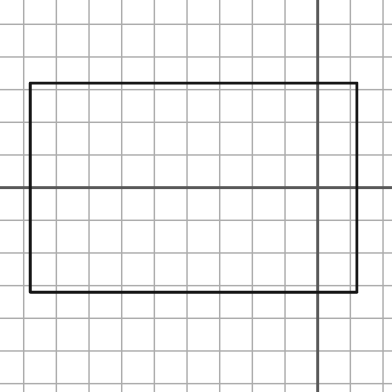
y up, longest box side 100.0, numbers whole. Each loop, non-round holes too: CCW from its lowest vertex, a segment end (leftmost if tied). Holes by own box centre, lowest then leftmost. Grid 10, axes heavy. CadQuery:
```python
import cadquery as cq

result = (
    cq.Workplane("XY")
    .moveTo(-88.0, -32.0)
    .lineTo(12.0, -32.0)
    .lineTo(12.0, 32.0)
    .lineTo(-88.0, 32.0)
    .close()
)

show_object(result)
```